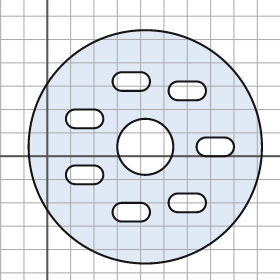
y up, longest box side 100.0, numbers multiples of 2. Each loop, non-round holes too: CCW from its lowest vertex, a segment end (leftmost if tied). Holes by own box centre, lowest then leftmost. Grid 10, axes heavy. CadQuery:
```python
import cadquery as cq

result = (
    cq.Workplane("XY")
    .moveTo(42.0, 4.0)
    .circle(50.0)
    .moveTo(32.0, -28.0)
    .lineTo(40.0, -28.0)
    .threePointArc((44.0, -24.0), (40.0, -20.0))
    .lineTo(32.0, -20.0)
    .threePointArc((28.0, -24.0), (32.0, -28.0))
    .close()
    .moveTo(56.0, -24.0)
    .lineTo(64.0, -24.0)
    .threePointArc((68.0, -20.0), (64.0, -16.0))
    .lineTo(56.0, -16.0)
    .threePointArc((52.0, -20.0), (56.0, -24.0))
    .close()
    .moveTo(12.0, -12.0)
    .lineTo(20.0, -12.0)
    .threePointArc((24.0, -8.0), (20.0, -4.0))
    .lineTo(12.0, -4.0)
    .threePointArc((8.0, -8.0), (12.0, -12.0))
    .close()
    .moveTo(42.0, 4.0)
    .circle(12.0)
    .moveTo(68.0, 0.0)
    .lineTo(76.0, 0.0)
    .threePointArc((80.0, 4.0), (76.0, 8.0))
    .lineTo(68.0, 8.0)
    .threePointArc((64.0, 4.0), (68.0, 0.0))
    .close()
    .moveTo(12.0, 12.0)
    .lineTo(20.0, 12.0)
    .threePointArc((24.0, 16.0), (20.0, 20.0))
    .lineTo(12.0, 20.0)
    .threePointArc((8.0, 16.0), (12.0, 12.0))
    .close()
    .moveTo(56.0, 24.0)
    .lineTo(64.0, 24.0)
    .threePointArc((68.0, 28.0), (64.0, 32.0))
    .lineTo(56.0, 32.0)
    .threePointArc((52.0, 28.0), (56.0, 24.0))
    .close()
    .moveTo(32.0, 28.0)
    .lineTo(40.0, 28.0)
    .threePointArc((44.0, 32.0), (40.0, 36.0))
    .lineTo(32.0, 36.0)
    .threePointArc((28.0, 32.0), (32.0, 28.0))
    .close()
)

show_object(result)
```